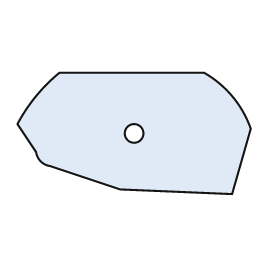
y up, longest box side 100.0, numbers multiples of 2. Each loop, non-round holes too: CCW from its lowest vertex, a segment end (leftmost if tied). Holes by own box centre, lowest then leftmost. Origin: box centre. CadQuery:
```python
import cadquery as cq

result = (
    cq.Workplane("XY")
    .moveTo(42.0, -26.0)
    .lineTo(50.0, 2.0)
    .threePointArc((42.0, 16.0), (30.0, 26.0))
    .lineTo(-32.0, 26.0)
    .threePointArc((-42.0, 16.0), (-50.0, 4.0))
    .lineTo(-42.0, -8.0)
    .threePointArc((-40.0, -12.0), (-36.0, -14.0))
    .lineTo(-6.0, -24.0)
    .close()
    .moveTo(0.0, 0.0)
    .circle(4.0)
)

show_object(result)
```